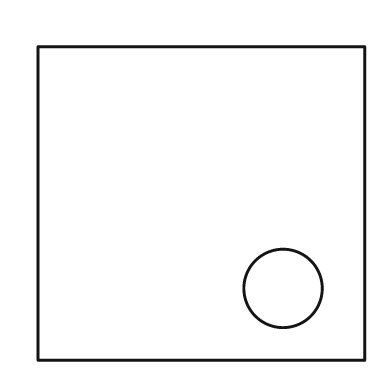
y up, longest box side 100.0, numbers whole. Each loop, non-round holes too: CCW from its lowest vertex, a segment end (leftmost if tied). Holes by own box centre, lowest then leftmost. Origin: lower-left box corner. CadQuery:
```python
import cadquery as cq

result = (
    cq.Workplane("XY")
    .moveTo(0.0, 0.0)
    .lineTo(100.0, 0.0)
    .lineTo(100.0, 96.0)
    .lineTo(0.0, 96.0)
    .close()
    .moveTo(75.0, 22.0)
    .circle(12.0)
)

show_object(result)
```